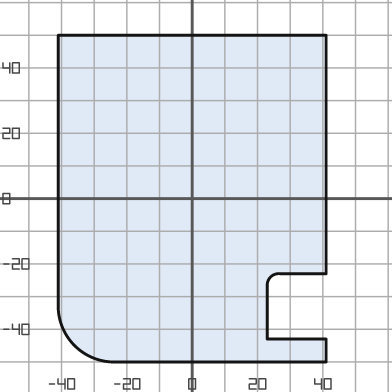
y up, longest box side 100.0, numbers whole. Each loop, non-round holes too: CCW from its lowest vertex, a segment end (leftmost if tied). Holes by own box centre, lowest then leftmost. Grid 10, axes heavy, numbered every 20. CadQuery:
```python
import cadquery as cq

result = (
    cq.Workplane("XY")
    .moveTo(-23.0, -50.0)
    .lineTo(41.0, -50.0)
    .lineTo(41.0, -43.0)
    .lineTo(23.0, -43.0)
    .lineTo(23.0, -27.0)
    .threePointArc((24.0, -24.0), (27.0, -23.0))
    .lineTo(41.0, -23.0)
    .lineTo(41.0, 50.0)
    .lineTo(-41.0, 50.0)
    .lineTo(-41.0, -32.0)
    .threePointArc((-36.0, -45.0), (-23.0, -50.0))
    .close()
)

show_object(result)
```